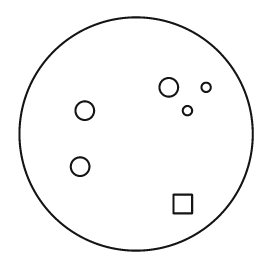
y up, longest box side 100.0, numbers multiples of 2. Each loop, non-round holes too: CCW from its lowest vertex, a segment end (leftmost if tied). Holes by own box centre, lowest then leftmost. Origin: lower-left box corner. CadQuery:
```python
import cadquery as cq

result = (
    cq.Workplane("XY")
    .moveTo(50.0, 50.0)
    .circle(50.0)
    .moveTo(66.0, 16.0)
    .lineTo(74.0, 16.0)
    .lineTo(74.0, 24.0)
    .lineTo(66.0, 24.0)
    .close()
    .moveTo(26.0, 36.0)
    .circle(4.0)
    .moveTo(28.0, 60.0)
    .circle(4.0)
    .moveTo(72.0, 60.0)
    .circle(2.0)
    .moveTo(64.0, 70.0)
    .circle(4.0)
    .moveTo(80.0, 70.0)
    .circle(2.0)
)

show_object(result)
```